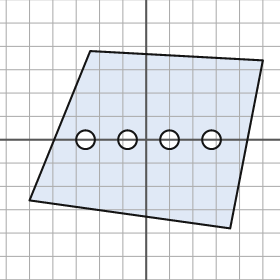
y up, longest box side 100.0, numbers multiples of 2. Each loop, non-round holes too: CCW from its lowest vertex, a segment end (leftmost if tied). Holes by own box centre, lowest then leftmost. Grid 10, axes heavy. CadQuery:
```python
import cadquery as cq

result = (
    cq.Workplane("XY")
    .moveTo(36.0, -38.0)
    .lineTo(50.0, 34.0)
    .lineTo(-24.0, 38.0)
    .lineTo(-50.0, -26.0)
    .close()
    .moveTo(-26.0, 0.0)
    .circle(4.0)
    .moveTo(-8.0, 0.0)
    .circle(4.0)
    .moveTo(10.0, 0.0)
    .circle(4.0)
    .moveTo(28.0, 0.0)
    .circle(4.0)
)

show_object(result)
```